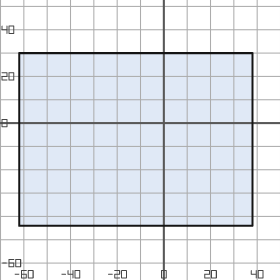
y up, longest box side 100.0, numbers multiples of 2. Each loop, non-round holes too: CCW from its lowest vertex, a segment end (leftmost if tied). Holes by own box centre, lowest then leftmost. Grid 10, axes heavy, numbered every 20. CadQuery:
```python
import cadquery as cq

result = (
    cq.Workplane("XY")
    .moveTo(-62.0, -44.0)
    .lineTo(38.0, -44.0)
    .lineTo(38.0, 30.0)
    .lineTo(-62.0, 30.0)
    .close()
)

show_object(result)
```